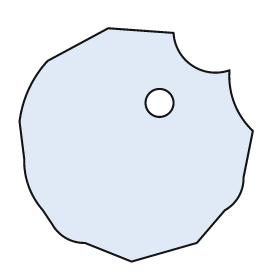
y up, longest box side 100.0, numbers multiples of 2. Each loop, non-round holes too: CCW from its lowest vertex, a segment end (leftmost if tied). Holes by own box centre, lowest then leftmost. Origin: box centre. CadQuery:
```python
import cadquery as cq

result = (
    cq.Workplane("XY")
    .moveTo(-2.0, -50.0)
    .lineTo(26.0, -42.0)
    .lineTo(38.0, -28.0)
    .threePointArc((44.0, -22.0), (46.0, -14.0))
    .lineTo(50.0, 6.0)
    .threePointArc((42.0, 18.0), (40.0, 32.0))
    .threePointArc((24.0, 34.0), (16.0, 48.0))
    .lineTo(-12.0, 50.0)
    .lineTo(-38.0, 36.0)
    .threePointArc((-46.0, 24.0), (-50.0, 10.0))
    .lineTo(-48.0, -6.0)
    .threePointArc((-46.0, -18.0), (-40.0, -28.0))
    .lineTo(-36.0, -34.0)
    .threePointArc((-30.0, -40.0), (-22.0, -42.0))
    .close()
    .moveTo(10.0, 18.0)
    .circle(6.0)
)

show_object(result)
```